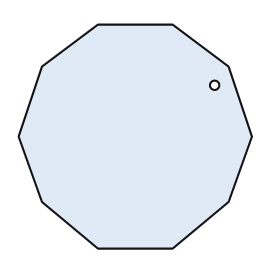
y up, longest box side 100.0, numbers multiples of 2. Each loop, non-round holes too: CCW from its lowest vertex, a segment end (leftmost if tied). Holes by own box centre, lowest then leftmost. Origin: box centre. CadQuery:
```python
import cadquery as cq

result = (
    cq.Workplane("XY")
    .moveTo(-16.0, -48.0)
    .lineTo(16.0, -48.0)
    .lineTo(40.0, -28.0)
    .lineTo(50.0, 0.0)
    .lineTo(40.0, 30.0)
    .lineTo(16.0, 48.0)
    .lineTo(-16.0, 48.0)
    .lineTo(-40.0, 30.0)
    .lineTo(-50.0, 0.0)
    .lineTo(-40.0, -28.0)
    .close()
    .moveTo(34.0, 22.0)
    .circle(2.0)
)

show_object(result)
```